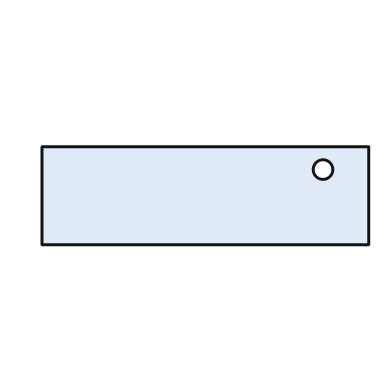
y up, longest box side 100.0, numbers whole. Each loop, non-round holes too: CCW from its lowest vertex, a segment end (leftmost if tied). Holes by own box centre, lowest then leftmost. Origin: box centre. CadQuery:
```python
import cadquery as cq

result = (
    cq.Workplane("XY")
    .moveTo(-50.0, -15.0)
    .lineTo(50.0, -15.0)
    .lineTo(50.0, 15.0)
    .lineTo(-50.0, 15.0)
    .close()
    .moveTo(36.0, 8.0)
    .circle(3.0)
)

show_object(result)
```